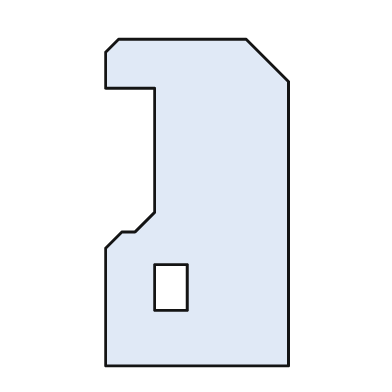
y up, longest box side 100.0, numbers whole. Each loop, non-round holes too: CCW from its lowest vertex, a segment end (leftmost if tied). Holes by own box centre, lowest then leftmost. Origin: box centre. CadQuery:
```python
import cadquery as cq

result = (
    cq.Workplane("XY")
    .moveTo(-28.0, -50.0)
    .lineTo(28.0, -50.0)
    .lineTo(28.0, 37.0)
    .lineTo(15.0, 50.0)
    .lineTo(-24.0, 50.0)
    .lineTo(-28.0, 46.0)
    .lineTo(-28.0, 35.0)
    .lineTo(-13.0, 35.0)
    .lineTo(-13.0, -3.0)
    .lineTo(-19.0, -9.0)
    .lineTo(-23.0, -9.0)
    .lineTo(-28.0, -14.0)
    .close()
    .moveTo(-13.0, -33.0)
    .lineTo(-3.0, -33.0)
    .lineTo(-3.0, -19.0)
    .lineTo(-13.0, -19.0)
    .close()
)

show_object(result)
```